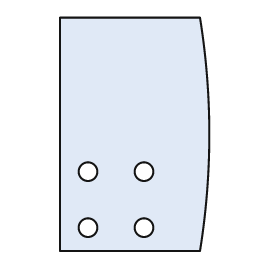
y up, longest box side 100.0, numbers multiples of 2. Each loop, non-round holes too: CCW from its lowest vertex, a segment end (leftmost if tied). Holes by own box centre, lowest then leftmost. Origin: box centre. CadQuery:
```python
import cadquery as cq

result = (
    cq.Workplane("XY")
    .moveTo(-32.0, -50.0)
    .lineTo(28.0, -50.0)
    .threePointArc((32.0, 0.0), (28.0, 50.0))
    .lineTo(-32.0, 50.0)
    .close()
    .moveTo(-20.0, -40.0)
    .circle(4.0)
    .moveTo(4.0, -40.0)
    .circle(4.0)
    .moveTo(-20.0, -16.0)
    .circle(4.0)
    .moveTo(4.0, -16.0)
    .circle(4.0)
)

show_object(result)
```